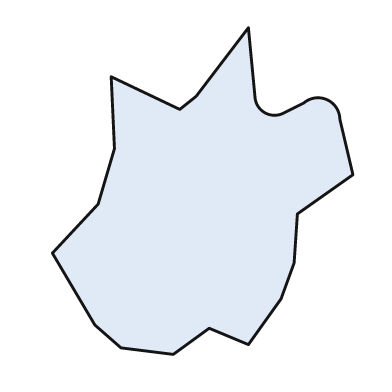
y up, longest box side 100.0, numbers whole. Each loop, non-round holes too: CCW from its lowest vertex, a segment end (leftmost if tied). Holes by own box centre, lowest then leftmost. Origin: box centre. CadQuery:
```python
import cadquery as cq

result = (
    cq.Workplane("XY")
    .moveTo(-9.0, -50.0)
    .lineTo(2.0, -42.0)
    .lineTo(14.0, -47.0)
    .lineTo(24.0, -33.0)
    .lineTo(28.0, -22.0)
    .lineTo(29.0, -7.0)
    .lineTo(46.0, 5.0)
    .lineTo(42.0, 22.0)
    .threePointArc((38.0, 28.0), (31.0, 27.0))
    .lineTo(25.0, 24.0)
    .threePointArc((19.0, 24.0), (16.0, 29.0))
    .lineTo(14.0, 50.0)
    .lineTo(-2.0, 29.0)
    .lineTo(-7.0, 25.0)
    .lineTo(-28.0, 35.0)
    .lineTo(-27.0, 13.0)
    .lineTo(-32.0, -4.0)
    .lineTo(-46.0, -19.0)
    .lineTo(-33.0, -41.0)
    .lineTo(-25.0, -48.0)
    .close()
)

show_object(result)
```